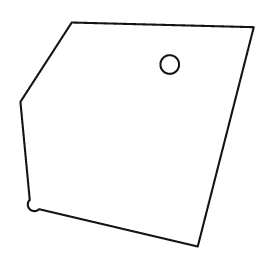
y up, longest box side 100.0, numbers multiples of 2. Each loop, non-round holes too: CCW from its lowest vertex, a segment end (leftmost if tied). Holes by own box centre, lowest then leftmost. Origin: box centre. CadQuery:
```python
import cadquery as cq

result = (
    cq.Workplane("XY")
    .moveTo(26.0, -48.0)
    .lineTo(50.0, 46.0)
    .lineTo(-28.0, 48.0)
    .lineTo(-50.0, 14.0)
    .lineTo(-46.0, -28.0)
    .threePointArc((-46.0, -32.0), (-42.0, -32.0))
    .close()
    .moveTo(14.0, 30.0)
    .circle(4.0)
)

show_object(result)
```